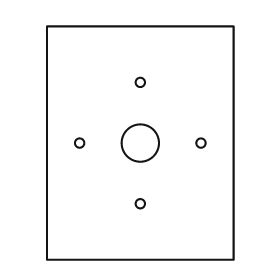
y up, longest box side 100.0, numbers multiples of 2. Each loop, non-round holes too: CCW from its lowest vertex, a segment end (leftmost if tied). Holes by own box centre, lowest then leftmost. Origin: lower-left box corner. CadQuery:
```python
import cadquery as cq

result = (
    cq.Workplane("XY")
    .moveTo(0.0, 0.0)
    .lineTo(80.0, 0.0)
    .lineTo(80.0, 100.0)
    .lineTo(0.0, 100.0)
    .close()
    .moveTo(40.0, 24.0)
    .circle(2.0)
    .moveTo(14.0, 50.0)
    .circle(2.0)
    .moveTo(40.0, 50.0)
    .circle(8.0)
    .moveTo(66.0, 50.0)
    .circle(2.0)
    .moveTo(40.0, 76.0)
    .circle(2.0)
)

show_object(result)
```